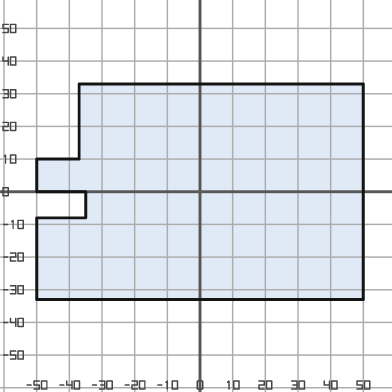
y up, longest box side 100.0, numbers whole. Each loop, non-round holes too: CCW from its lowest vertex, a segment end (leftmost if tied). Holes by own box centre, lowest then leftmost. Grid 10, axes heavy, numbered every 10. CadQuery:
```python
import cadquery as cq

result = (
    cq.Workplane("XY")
    .moveTo(-50.0, -33.0)
    .lineTo(50.0, -33.0)
    .lineTo(50.0, 33.0)
    .lineTo(-37.0, 33.0)
    .lineTo(-37.0, 10.0)
    .lineTo(-50.0, 10.0)
    .lineTo(-50.0, 0.0)
    .lineTo(-35.0, 0.0)
    .lineTo(-35.0, -8.0)
    .lineTo(-50.0, -8.0)
    .close()
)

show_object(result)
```